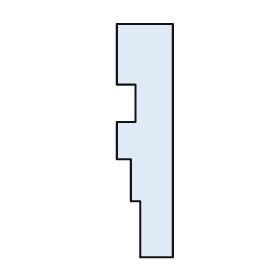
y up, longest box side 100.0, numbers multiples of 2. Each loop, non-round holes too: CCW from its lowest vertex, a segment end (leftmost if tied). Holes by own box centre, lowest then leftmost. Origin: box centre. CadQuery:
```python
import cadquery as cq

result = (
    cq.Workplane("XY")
    .moveTo(-2.0, -50.0)
    .lineTo(12.0, -50.0)
    .lineTo(12.0, 50.0)
    .lineTo(-12.0, 50.0)
    .lineTo(-12.0, 24.0)
    .lineTo(-4.0, 24.0)
    .lineTo(-4.0, 8.0)
    .lineTo(-12.0, 8.0)
    .lineTo(-12.0, -8.0)
    .lineTo(-6.0, -8.0)
    .lineTo(-6.0, -26.0)
    .lineTo(-2.0, -26.0)
    .close()
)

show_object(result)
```